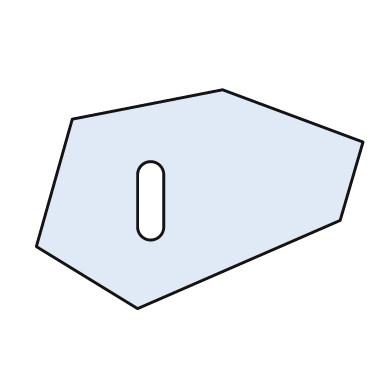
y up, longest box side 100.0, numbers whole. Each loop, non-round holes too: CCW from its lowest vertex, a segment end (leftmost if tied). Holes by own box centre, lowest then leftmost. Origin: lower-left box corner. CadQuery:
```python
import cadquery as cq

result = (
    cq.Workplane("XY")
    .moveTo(31.0, 0.0)
    .lineTo(93.0, 27.0)
    .lineTo(100.0, 51.0)
    .lineTo(57.0, 67.0)
    .lineTo(11.0, 58.0)
    .lineTo(0.0, 19.0)
    .close()
    .moveTo(31.0, 25.0)
    .threePointArc((35.0, 21.0), (39.0, 25.0))
    .lineTo(39.0, 41.0)
    .threePointArc((35.0, 45.0), (31.0, 41.0))
    .close()
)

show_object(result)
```